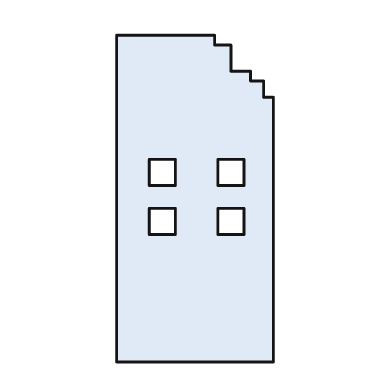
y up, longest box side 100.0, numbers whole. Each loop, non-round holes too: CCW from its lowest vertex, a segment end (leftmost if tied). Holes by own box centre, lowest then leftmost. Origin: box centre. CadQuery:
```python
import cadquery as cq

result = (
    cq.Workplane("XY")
    .moveTo(-24.0, -50.0)
    .lineTo(24.0, -50.0)
    .lineTo(24.0, 31.0)
    .lineTo(21.0, 31.0)
    .lineTo(21.0, 36.0)
    .lineTo(17.0, 36.0)
    .lineTo(17.0, 39.0)
    .lineTo(11.0, 39.0)
    .lineTo(11.0, 47.0)
    .lineTo(6.0, 47.0)
    .lineTo(6.0, 50.0)
    .lineTo(-24.0, 50.0)
    .close()
    .moveTo(-14.0, -11.0)
    .lineTo(-6.0, -11.0)
    .lineTo(-6.0, -3.0)
    .lineTo(-14.0, -3.0)
    .close()
    .moveTo(7.0, -11.0)
    .lineTo(15.0, -11.0)
    .lineTo(15.0, -3.0)
    .lineTo(7.0, -3.0)
    .close()
    .moveTo(-14.0, 4.0)
    .lineTo(-6.0, 4.0)
    .lineTo(-6.0, 12.0)
    .lineTo(-14.0, 12.0)
    .close()
    .moveTo(7.0, 4.0)
    .lineTo(15.0, 4.0)
    .lineTo(15.0, 12.0)
    .lineTo(7.0, 12.0)
    .close()
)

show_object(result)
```